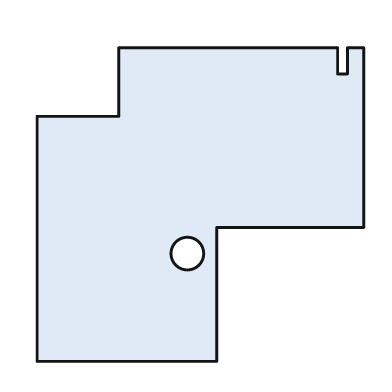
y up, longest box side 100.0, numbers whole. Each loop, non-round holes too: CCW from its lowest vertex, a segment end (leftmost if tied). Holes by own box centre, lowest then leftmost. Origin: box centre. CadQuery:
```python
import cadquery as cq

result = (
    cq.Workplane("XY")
    .moveTo(-50.0, -48.0)
    .lineTo(5.0, -48.0)
    .lineTo(5.0, -7.0)
    .lineTo(50.0, -7.0)
    .lineTo(50.0, 48.0)
    .lineTo(45.0, 48.0)
    .lineTo(45.0, 40.0)
    .lineTo(42.0, 40.0)
    .lineTo(42.0, 48.0)
    .lineTo(-25.0, 48.0)
    .lineTo(-25.0, 27.0)
    .lineTo(-50.0, 27.0)
    .close()
    .moveTo(-4.0, -15.0)
    .circle(5.0)
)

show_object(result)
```